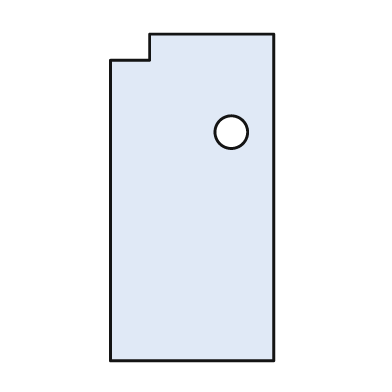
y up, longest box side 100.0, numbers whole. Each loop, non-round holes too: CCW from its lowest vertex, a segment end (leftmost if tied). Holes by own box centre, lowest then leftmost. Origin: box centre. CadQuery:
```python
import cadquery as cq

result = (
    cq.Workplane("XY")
    .moveTo(-25.0, -50.0)
    .lineTo(25.0, -50.0)
    .lineTo(25.0, 50.0)
    .lineTo(-13.0, 50.0)
    .lineTo(-13.0, 42.0)
    .lineTo(-25.0, 42.0)
    .close()
    .moveTo(12.0, 20.0)
    .circle(5.0)
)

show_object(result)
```